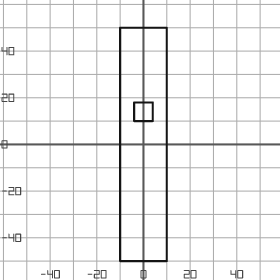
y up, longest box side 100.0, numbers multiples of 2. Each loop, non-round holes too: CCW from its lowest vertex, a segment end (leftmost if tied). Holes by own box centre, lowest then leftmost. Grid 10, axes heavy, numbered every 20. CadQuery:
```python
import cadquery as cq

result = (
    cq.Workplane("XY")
    .moveTo(-10.0, -50.0)
    .lineTo(10.0, -50.0)
    .lineTo(10.0, 50.0)
    .lineTo(-10.0, 50.0)
    .close()
    .moveTo(-4.0, 10.0)
    .lineTo(4.0, 10.0)
    .lineTo(4.0, 18.0)
    .lineTo(-4.0, 18.0)
    .close()
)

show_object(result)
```